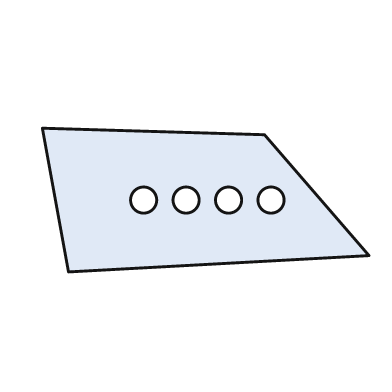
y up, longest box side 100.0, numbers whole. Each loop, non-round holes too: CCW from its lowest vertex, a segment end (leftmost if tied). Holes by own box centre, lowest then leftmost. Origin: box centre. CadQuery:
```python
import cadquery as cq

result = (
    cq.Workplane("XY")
    .moveTo(-42.0, -22.0)
    .lineTo(50.0, -17.0)
    .lineTo(18.0, 20.0)
    .lineTo(-50.0, 22.0)
    .close()
    .moveTo(-19.0, 0.0)
    .circle(4.0)
    .moveTo(-6.0, 0.0)
    .circle(4.0)
    .moveTo(7.0, 0.0)
    .circle(4.0)
    .moveTo(20.0, 0.0)
    .circle(4.0)
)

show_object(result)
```